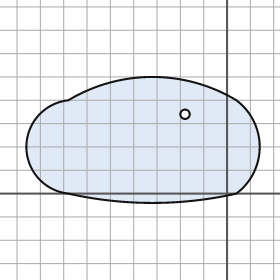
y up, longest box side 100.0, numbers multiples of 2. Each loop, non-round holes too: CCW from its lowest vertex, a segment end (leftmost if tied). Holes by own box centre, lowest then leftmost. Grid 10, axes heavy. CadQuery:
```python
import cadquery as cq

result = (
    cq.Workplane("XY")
    .moveTo(-68.0, 0.0)
    .threePointArc((-32.0, -4.0), (4.0, 0.0))
    .threePointArc((14.0, 20.0), (4.0, 40.0))
    .threePointArc((-32.0, 50.0), (-68.0, 40.0))
    .threePointArc((-86.0, 20.0), (-68.0, 0.0))
    .close()
    .moveTo(-18.0, 34.0)
    .circle(2.0)
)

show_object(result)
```